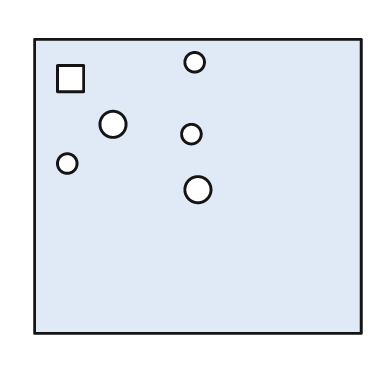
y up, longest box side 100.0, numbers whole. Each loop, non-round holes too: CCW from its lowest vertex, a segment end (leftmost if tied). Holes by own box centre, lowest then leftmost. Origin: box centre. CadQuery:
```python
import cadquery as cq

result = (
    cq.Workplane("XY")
    .moveTo(-50.0, -45.0)
    .lineTo(50.0, -45.0)
    .lineTo(50.0, 45.0)
    .lineTo(-50.0, 45.0)
    .close()
    .moveTo(0.0, -1.0)
    .circle(4.0)
    .moveTo(-40.0, 7.0)
    .circle(3.0)
    .moveTo(-2.0, 16.0)
    .circle(3.0)
    .moveTo(-26.0, 19.0)
    .circle(4.0)
    .moveTo(-43.0, 29.0)
    .lineTo(-35.0, 29.0)
    .lineTo(-35.0, 37.0)
    .lineTo(-43.0, 37.0)
    .close()
    .moveTo(-1.0, 38.0)
    .circle(3.0)
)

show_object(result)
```